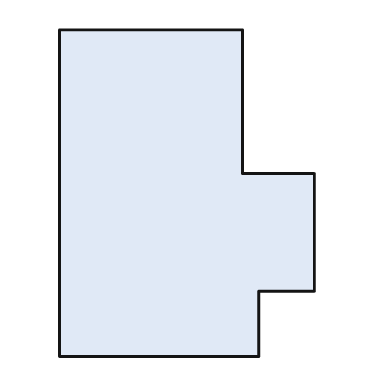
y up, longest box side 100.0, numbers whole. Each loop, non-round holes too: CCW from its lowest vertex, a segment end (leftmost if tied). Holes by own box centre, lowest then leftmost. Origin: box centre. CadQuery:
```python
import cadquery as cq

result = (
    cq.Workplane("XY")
    .moveTo(-39.0, -50.0)
    .lineTo(22.0, -50.0)
    .lineTo(22.0, -30.0)
    .lineTo(39.0, -30.0)
    .lineTo(39.0, 6.0)
    .lineTo(17.0, 6.0)
    .lineTo(17.0, 50.0)
    .lineTo(-39.0, 50.0)
    .close()
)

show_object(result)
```